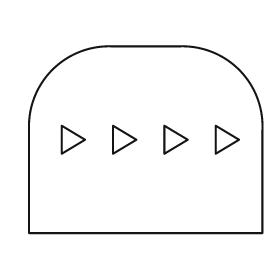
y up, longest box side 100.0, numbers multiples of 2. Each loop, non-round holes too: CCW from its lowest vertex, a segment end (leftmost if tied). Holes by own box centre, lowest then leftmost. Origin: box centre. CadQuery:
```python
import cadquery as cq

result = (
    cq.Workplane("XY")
    .moveTo(-50.0, -40.0)
    .lineTo(50.0, -40.0)
    .lineTo(50.0, 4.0)
    .threePointArc((40.0, 30.0), (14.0, 40.0))
    .lineTo(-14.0, 40.0)
    .threePointArc((-40.0, 30.0), (-50.0, 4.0))
    .close()
    .moveTo(-36.0, -6.0)
    .lineTo(-26.0, 0.0)
    .lineTo(-36.0, 6.0)
    .close()
    .moveTo(-14.0, -6.0)
    .lineTo(-4.0, 0.0)
    .lineTo(-14.0, 6.0)
    .close()
    .moveTo(8.0, -6.0)
    .lineTo(18.0, 0.0)
    .lineTo(8.0, 6.0)
    .close()
    .moveTo(30.0, -6.0)
    .lineTo(40.0, 0.0)
    .lineTo(30.0, 6.0)
    .close()
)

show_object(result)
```